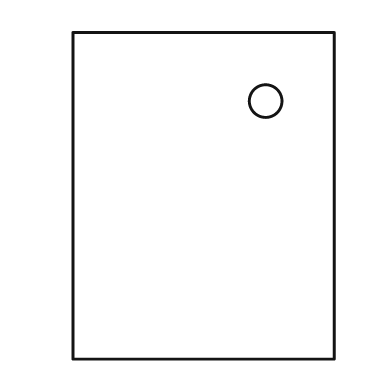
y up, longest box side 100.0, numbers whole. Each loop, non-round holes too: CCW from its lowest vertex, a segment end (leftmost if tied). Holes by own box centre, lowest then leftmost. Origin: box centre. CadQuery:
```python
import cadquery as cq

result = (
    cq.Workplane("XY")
    .moveTo(-40.0, -50.0)
    .lineTo(40.0, -50.0)
    .lineTo(40.0, 50.0)
    .lineTo(-40.0, 50.0)
    .close()
    .moveTo(19.0, 29.0)
    .circle(5.0)
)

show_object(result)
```